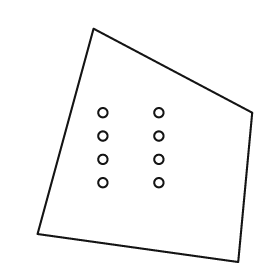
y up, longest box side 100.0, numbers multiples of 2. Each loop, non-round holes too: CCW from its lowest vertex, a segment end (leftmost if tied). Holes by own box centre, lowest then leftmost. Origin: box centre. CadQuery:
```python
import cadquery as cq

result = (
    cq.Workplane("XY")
    .moveTo(40.0, -50.0)
    .lineTo(46.0, 14.0)
    .lineTo(-22.0, 50.0)
    .lineTo(-46.0, -38.0)
    .close()
    .moveTo(-18.0, -16.0)
    .circle(2.0)
    .moveTo(6.0, -16.0)
    .circle(2.0)
    .moveTo(-18.0, -6.0)
    .circle(2.0)
    .moveTo(6.0, -6.0)
    .circle(2.0)
    .moveTo(-18.0, 4.0)
    .circle(2.0)
    .moveTo(6.0, 4.0)
    .circle(2.0)
    .moveTo(-18.0, 14.0)
    .circle(2.0)
    .moveTo(6.0, 14.0)
    .circle(2.0)
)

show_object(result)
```